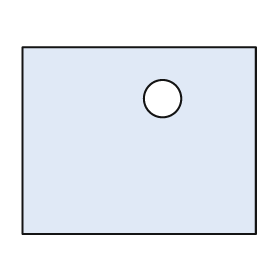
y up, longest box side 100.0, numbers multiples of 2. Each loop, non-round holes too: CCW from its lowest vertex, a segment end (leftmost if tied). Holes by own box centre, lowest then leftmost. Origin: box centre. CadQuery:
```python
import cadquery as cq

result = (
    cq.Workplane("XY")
    .moveTo(-50.0, -40.0)
    .lineTo(50.0, -40.0)
    .lineTo(50.0, 40.0)
    .lineTo(-50.0, 40.0)
    .close()
    .moveTo(10.0, 18.0)
    .circle(8.0)
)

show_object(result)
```